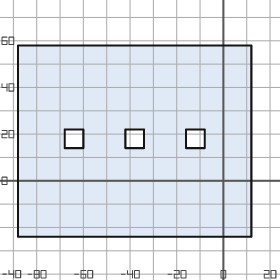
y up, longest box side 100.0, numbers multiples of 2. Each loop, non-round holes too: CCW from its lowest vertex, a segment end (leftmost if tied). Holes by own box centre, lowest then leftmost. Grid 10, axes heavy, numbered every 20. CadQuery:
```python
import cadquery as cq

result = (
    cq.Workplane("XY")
    .moveTo(-88.0, -24.0)
    .lineTo(12.0, -24.0)
    .lineTo(12.0, 58.0)
    .lineTo(-88.0, 58.0)
    .close()
    .moveTo(-68.0, 14.0)
    .lineTo(-60.0, 14.0)
    .lineTo(-60.0, 22.0)
    .lineTo(-68.0, 22.0)
    .close()
    .moveTo(-42.0, 14.0)
    .lineTo(-34.0, 14.0)
    .lineTo(-34.0, 22.0)
    .lineTo(-42.0, 22.0)
    .close()
    .moveTo(-16.0, 14.0)
    .lineTo(-8.0, 14.0)
    .lineTo(-8.0, 22.0)
    .lineTo(-16.0, 22.0)
    .close()
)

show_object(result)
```